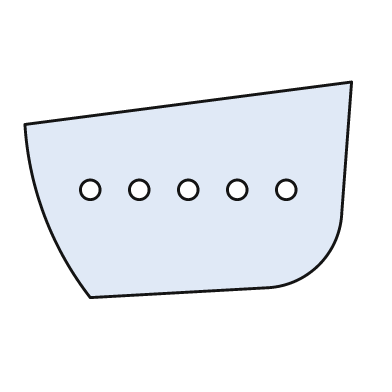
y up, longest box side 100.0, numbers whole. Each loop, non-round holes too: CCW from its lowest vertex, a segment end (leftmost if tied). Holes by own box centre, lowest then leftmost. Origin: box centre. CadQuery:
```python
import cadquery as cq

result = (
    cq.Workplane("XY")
    .moveTo(-30.0, -33.0)
    .lineTo(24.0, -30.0)
    .threePointArc((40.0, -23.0), (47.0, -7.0))
    .lineTo(50.0, 33.0)
    .lineTo(-50.0, 20.0)
    .threePointArc((-44.0, -8.0), (-30.0, -33.0))
    .close()
    .moveTo(-30.0, 0.0)
    .circle(3.0)
    .moveTo(-15.0, 0.0)
    .circle(3.0)
    .moveTo(0.0, 0.0)
    .circle(3.0)
    .moveTo(15.0, 0.0)
    .circle(3.0)
    .moveTo(30.0, 0.0)
    .circle(3.0)
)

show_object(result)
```